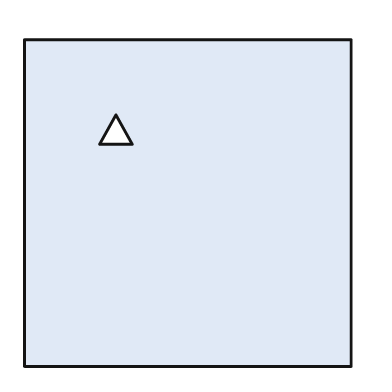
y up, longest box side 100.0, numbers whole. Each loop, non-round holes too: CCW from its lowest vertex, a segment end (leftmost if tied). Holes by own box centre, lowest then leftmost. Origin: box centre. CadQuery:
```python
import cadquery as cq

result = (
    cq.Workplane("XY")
    .moveTo(-50.0, -50.0)
    .lineTo(50.0, -50.0)
    .lineTo(50.0, 50.0)
    .lineTo(-50.0, 50.0)
    .close()
    .moveTo(-27.0, 18.0)
    .lineTo(-17.0, 18.0)
    .lineTo(-22.0, 27.0)
    .close()
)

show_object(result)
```